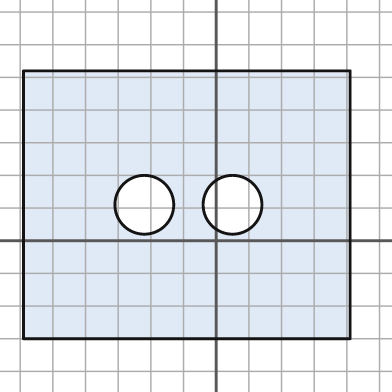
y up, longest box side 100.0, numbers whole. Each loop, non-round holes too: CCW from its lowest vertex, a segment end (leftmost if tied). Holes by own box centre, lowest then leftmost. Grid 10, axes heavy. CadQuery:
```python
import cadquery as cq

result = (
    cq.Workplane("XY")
    .moveTo(-59.0, -30.0)
    .lineTo(41.0, -30.0)
    .lineTo(41.0, 52.0)
    .lineTo(-59.0, 52.0)
    .close()
    .moveTo(-22.0, 11.0)
    .circle(9.0)
    .moveTo(5.0, 11.0)
    .circle(9.0)
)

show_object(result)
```